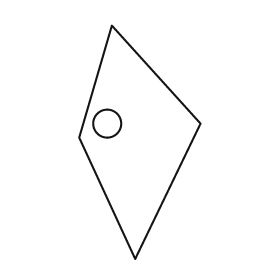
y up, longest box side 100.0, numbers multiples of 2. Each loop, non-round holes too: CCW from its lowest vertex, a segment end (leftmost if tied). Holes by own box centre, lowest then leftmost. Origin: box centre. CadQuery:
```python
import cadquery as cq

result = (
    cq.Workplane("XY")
    .moveTo(-2.0, -50.0)
    .lineTo(26.0, 8.0)
    .lineTo(-12.0, 50.0)
    .lineTo(-26.0, 2.0)
    .close()
    .moveTo(-14.0, 8.0)
    .circle(6.0)
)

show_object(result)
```